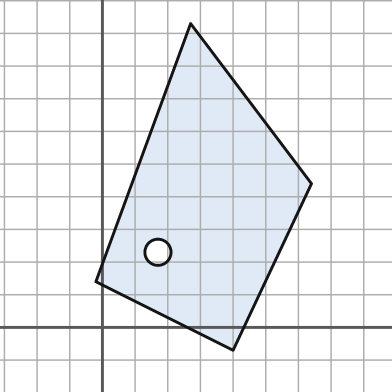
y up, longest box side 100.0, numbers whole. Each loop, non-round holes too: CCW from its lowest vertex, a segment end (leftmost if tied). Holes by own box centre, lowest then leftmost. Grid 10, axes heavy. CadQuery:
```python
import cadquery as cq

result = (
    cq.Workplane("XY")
    .moveTo(40.0, -7.0)
    .lineTo(64.0, 44.0)
    .lineTo(27.0, 93.0)
    .lineTo(-2.0, 14.0)
    .close()
    .moveTo(17.0, 23.0)
    .circle(4.0)
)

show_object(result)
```